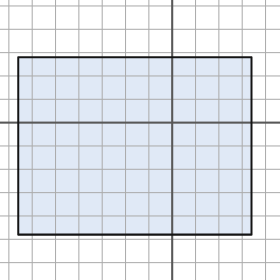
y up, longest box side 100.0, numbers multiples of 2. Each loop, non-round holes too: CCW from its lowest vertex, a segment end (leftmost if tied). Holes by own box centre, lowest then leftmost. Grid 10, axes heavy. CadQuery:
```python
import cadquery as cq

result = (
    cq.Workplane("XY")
    .moveTo(-66.0, -48.0)
    .lineTo(34.0, -48.0)
    .lineTo(34.0, 28.0)
    .lineTo(-66.0, 28.0)
    .close()
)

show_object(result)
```